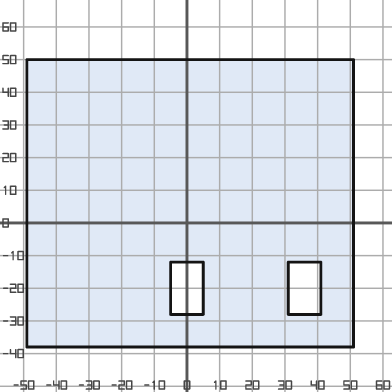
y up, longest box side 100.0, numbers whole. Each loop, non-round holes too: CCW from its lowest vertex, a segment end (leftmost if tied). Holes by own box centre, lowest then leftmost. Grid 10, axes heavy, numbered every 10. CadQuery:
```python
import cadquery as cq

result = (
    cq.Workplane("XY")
    .moveTo(-49.0, -38.0)
    .lineTo(51.0, -38.0)
    .lineTo(51.0, 50.0)
    .lineTo(-49.0, 50.0)
    .close()
    .moveTo(-5.0, -28.0)
    .lineTo(5.0, -28.0)
    .lineTo(5.0, -12.0)
    .lineTo(-5.0, -12.0)
    .close()
    .moveTo(31.0, -28.0)
    .lineTo(41.0, -28.0)
    .lineTo(41.0, -12.0)
    .lineTo(31.0, -12.0)
    .close()
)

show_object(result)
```